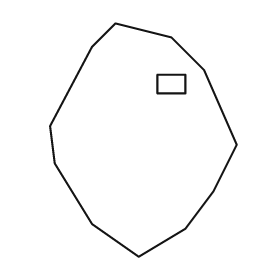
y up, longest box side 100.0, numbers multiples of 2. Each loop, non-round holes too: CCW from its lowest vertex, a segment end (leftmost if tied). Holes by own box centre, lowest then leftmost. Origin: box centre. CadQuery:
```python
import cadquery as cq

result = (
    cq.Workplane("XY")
    .moveTo(-2.0, -50.0)
    .lineTo(18.0, -38.0)
    .lineTo(30.0, -22.0)
    .lineTo(40.0, -2.0)
    .lineTo(26.0, 30.0)
    .lineTo(12.0, 44.0)
    .lineTo(-12.0, 50.0)
    .lineTo(-22.0, 40.0)
    .lineTo(-40.0, 6.0)
    .lineTo(-38.0, -10.0)
    .lineTo(-22.0, -36.0)
    .close()
    .moveTo(6.0, 20.0)
    .lineTo(18.0, 20.0)
    .lineTo(18.0, 28.0)
    .lineTo(6.0, 28.0)
    .close()
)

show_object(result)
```